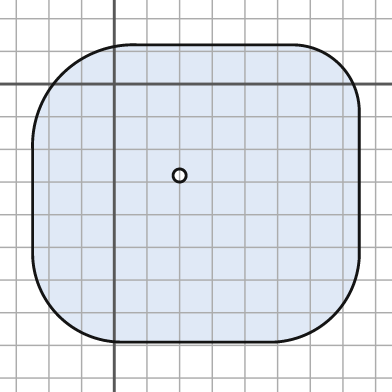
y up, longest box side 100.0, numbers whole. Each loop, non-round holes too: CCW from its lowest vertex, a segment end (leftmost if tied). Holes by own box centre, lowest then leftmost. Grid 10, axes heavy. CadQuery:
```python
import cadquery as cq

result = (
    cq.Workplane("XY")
    .moveTo(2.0, -79.0)
    .lineTo(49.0, -79.0)
    .threePointArc((67.0, -71.0), (75.0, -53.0))
    .lineTo(75.0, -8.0)
    .threePointArc((69.0, 6.0), (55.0, 12.0))
    .lineTo(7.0, 12.0)
    .threePointArc((-16.0, 3.0), (-25.0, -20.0))
    .lineTo(-25.0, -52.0)
    .threePointArc((-17.0, -71.0), (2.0, -79.0))
    .close()
    .moveTo(20.0, -28.0)
    .circle(2.0)
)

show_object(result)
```